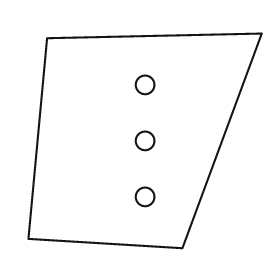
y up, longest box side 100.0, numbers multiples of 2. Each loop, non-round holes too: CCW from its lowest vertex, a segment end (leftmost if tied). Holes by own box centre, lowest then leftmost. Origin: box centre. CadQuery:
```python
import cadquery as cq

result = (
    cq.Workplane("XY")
    .moveTo(16.0, -46.0)
    .lineTo(50.0, 46.0)
    .lineTo(-42.0, 44.0)
    .lineTo(-50.0, -42.0)
    .close()
    .moveTo(0.0, -24.0)
    .circle(4.0)
    .moveTo(0.0, 0.0)
    .circle(4.0)
    .moveTo(0.0, 24.0)
    .circle(4.0)
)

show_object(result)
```